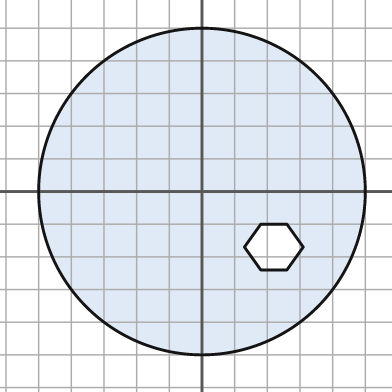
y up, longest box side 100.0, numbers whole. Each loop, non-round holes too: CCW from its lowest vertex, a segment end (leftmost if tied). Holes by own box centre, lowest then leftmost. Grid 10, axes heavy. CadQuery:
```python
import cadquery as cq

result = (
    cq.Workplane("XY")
    .moveTo(0.0, 0.0)
    .circle(50.0)
    .moveTo(18.0, -24.0)
    .lineTo(26.0, -24.0)
    .lineTo(31.0, -17.0)
    .lineTo(26.0, -10.0)
    .lineTo(18.0, -10.0)
    .lineTo(13.0, -17.0)
    .close()
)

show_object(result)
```